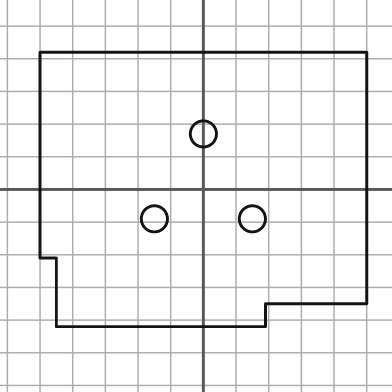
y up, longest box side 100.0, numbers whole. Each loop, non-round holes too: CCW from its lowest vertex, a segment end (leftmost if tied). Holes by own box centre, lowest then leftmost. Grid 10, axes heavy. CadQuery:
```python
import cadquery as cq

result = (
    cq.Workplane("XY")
    .moveTo(-45.0, -42.0)
    .lineTo(19.0, -42.0)
    .lineTo(19.0, -35.0)
    .lineTo(50.0, -35.0)
    .lineTo(50.0, 42.0)
    .lineTo(-50.0, 42.0)
    .lineTo(-50.0, -21.0)
    .lineTo(-45.0, -21.0)
    .close()
    .moveTo(-15.0, -9.0)
    .circle(4.0)
    .moveTo(15.0, -9.0)
    .circle(4.0)
    .moveTo(0.0, 17.0)
    .circle(4.0)
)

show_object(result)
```